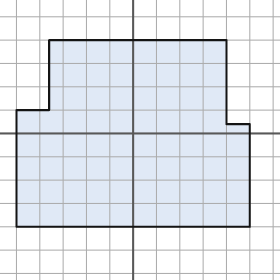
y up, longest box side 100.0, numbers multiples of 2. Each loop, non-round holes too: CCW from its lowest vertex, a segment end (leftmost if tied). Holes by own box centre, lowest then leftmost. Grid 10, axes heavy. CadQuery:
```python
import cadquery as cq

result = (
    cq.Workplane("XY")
    .moveTo(-50.0, -40.0)
    .lineTo(50.0, -40.0)
    .lineTo(50.0, 4.0)
    .lineTo(40.0, 4.0)
    .lineTo(40.0, 40.0)
    .lineTo(-36.0, 40.0)
    .lineTo(-36.0, 10.0)
    .lineTo(-50.0, 10.0)
    .close()
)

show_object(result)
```